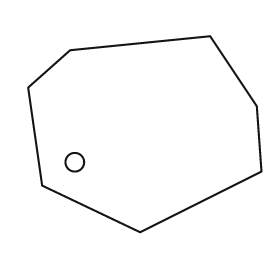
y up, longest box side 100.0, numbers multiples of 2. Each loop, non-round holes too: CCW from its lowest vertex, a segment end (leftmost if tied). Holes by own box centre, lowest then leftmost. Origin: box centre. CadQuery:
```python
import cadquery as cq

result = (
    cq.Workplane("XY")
    .moveTo(-2.0, -42.0)
    .lineTo(50.0, -16.0)
    .lineTo(48.0, 12.0)
    .lineTo(28.0, 42.0)
    .lineTo(-32.0, 36.0)
    .lineTo(-50.0, 20.0)
    .lineTo(-44.0, -22.0)
    .close()
    .moveTo(-30.0, -12.0)
    .circle(4.0)
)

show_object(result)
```